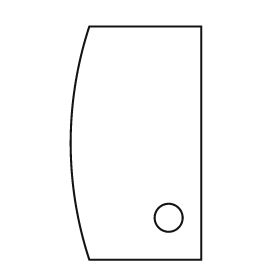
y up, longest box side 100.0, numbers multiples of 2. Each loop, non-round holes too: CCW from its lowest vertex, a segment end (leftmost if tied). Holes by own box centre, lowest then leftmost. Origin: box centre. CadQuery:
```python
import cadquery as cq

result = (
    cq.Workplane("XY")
    .moveTo(-20.0, -50.0)
    .lineTo(28.0, -50.0)
    .lineTo(28.0, 50.0)
    .lineTo(-20.0, 50.0)
    .threePointArc((-28.0, 0.0), (-20.0, -50.0))
    .close()
    .moveTo(14.0, -32.0)
    .circle(6.0)
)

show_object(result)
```